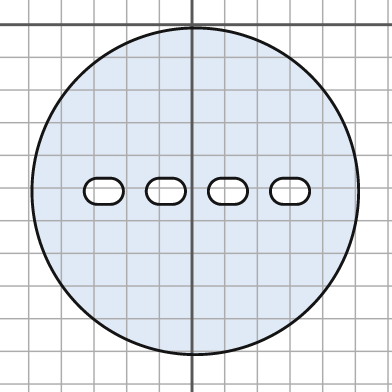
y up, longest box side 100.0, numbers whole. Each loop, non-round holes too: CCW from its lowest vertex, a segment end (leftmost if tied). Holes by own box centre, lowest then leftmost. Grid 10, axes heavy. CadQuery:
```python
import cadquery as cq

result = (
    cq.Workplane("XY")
    .moveTo(1.0, -51.0)
    .circle(50.0)
    .moveTo(-29.0, -55.0)
    .lineTo(-25.0, -55.0)
    .threePointArc((-21.0, -51.0), (-25.0, -47.0))
    .lineTo(-29.0, -47.0)
    .threePointArc((-33.0, -51.0), (-29.0, -55.0))
    .close()
    .moveTo(-10.0, -55.0)
    .lineTo(-6.0, -55.0)
    .threePointArc((-2.0, -51.0), (-6.0, -47.0))
    .lineTo(-10.0, -47.0)
    .threePointArc((-14.0, -51.0), (-10.0, -55.0))
    .close()
    .moveTo(9.0, -55.0)
    .lineTo(13.0, -55.0)
    .threePointArc((17.0, -51.0), (13.0, -47.0))
    .lineTo(9.0, -47.0)
    .threePointArc((5.0, -51.0), (9.0, -55.0))
    .close()
    .moveTo(28.0, -55.0)
    .lineTo(32.0, -55.0)
    .threePointArc((36.0, -51.0), (32.0, -47.0))
    .lineTo(28.0, -47.0)
    .threePointArc((24.0, -51.0), (28.0, -55.0))
    .close()
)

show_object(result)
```